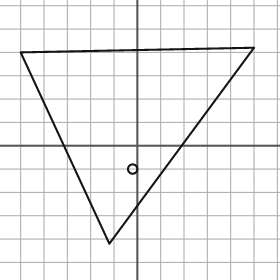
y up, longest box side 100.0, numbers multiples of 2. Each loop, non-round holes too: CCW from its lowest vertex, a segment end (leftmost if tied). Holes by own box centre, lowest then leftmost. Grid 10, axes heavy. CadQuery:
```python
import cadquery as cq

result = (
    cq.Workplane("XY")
    .moveTo(-12.0, -42.0)
    .lineTo(50.0, 42.0)
    .lineTo(-50.0, 40.0)
    .close()
    .moveTo(-2.0, -10.0)
    .circle(2.0)
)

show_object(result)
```